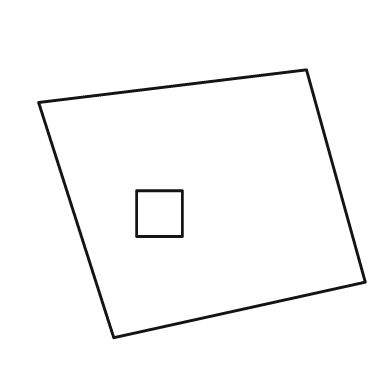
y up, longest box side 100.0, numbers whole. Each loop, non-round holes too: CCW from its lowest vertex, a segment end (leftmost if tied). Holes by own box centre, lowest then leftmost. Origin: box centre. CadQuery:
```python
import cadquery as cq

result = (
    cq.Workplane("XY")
    .moveTo(-27.0, -41.0)
    .lineTo(50.0, -24.0)
    .lineTo(32.0, 41.0)
    .lineTo(-50.0, 31.0)
    .close()
    .moveTo(-20.0, -10.0)
    .lineTo(-6.0, -10.0)
    .lineTo(-6.0, 4.0)
    .lineTo(-20.0, 4.0)
    .close()
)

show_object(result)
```